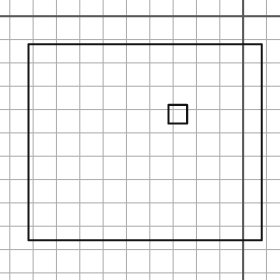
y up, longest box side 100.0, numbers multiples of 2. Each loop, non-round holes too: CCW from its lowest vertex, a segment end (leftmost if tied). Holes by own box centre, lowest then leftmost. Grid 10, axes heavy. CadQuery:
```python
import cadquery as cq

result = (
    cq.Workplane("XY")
    .moveTo(-92.0, -96.0)
    .lineTo(8.0, -96.0)
    .lineTo(8.0, -12.0)
    .lineTo(-92.0, -12.0)
    .close()
    .moveTo(-32.0, -46.0)
    .lineTo(-24.0, -46.0)
    .lineTo(-24.0, -38.0)
    .lineTo(-32.0, -38.0)
    .close()
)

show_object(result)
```